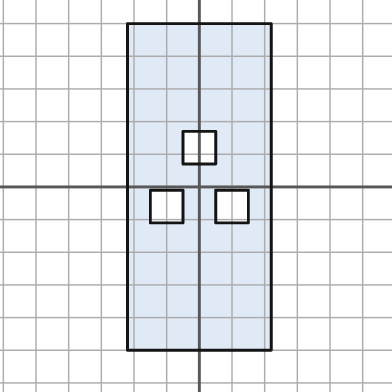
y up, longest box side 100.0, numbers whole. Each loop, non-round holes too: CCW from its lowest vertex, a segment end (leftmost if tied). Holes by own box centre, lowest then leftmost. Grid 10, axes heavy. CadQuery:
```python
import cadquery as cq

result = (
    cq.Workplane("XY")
    .moveTo(-22.0, -50.0)
    .lineTo(22.0, -50.0)
    .lineTo(22.0, 50.0)
    .lineTo(-22.0, 50.0)
    .close()
    .moveTo(-15.0, -11.0)
    .lineTo(-5.0, -11.0)
    .lineTo(-5.0, -1.0)
    .lineTo(-15.0, -1.0)
    .close()
    .moveTo(5.0, -11.0)
    .lineTo(15.0, -11.0)
    .lineTo(15.0, -1.0)
    .lineTo(5.0, -1.0)
    .close()
    .moveTo(-5.0, 7.0)
    .lineTo(5.0, 7.0)
    .lineTo(5.0, 17.0)
    .lineTo(-5.0, 17.0)
    .close()
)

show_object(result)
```